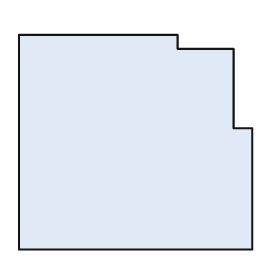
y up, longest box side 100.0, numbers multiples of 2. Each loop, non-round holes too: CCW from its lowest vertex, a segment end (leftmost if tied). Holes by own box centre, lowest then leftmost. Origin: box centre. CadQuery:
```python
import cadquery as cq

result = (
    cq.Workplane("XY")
    .moveTo(-50.0, -46.0)
    .lineTo(50.0, -46.0)
    .lineTo(50.0, 6.0)
    .lineTo(42.0, 6.0)
    .lineTo(42.0, 40.0)
    .lineTo(18.0, 40.0)
    .lineTo(18.0, 46.0)
    .lineTo(-50.0, 46.0)
    .close()
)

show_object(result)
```